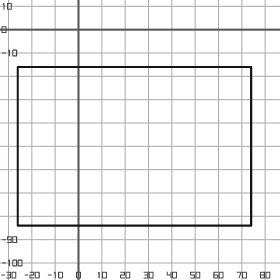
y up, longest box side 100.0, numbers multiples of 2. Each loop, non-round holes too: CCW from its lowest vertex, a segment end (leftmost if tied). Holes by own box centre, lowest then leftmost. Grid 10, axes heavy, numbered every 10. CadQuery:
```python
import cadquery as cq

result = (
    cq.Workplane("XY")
    .moveTo(-26.0, -84.0)
    .lineTo(74.0, -84.0)
    .lineTo(74.0, -16.0)
    .lineTo(-26.0, -16.0)
    .close()
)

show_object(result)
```